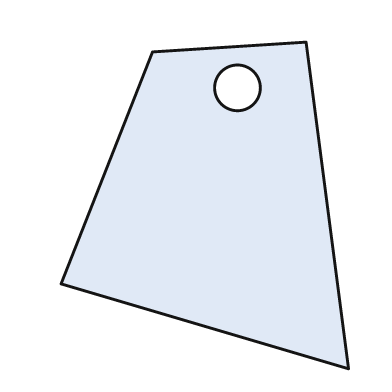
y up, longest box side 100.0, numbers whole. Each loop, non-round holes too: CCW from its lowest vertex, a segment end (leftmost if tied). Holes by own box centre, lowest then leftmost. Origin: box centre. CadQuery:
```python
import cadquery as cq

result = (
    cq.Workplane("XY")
    .moveTo(44.0, -50.0)
    .lineTo(31.0, 50.0)
    .lineTo(-16.0, 47.0)
    .lineTo(-44.0, -24.0)
    .close()
    .moveTo(10.0, 36.0)
    .circle(7.0)
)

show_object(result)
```